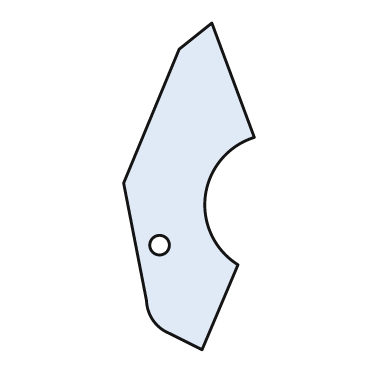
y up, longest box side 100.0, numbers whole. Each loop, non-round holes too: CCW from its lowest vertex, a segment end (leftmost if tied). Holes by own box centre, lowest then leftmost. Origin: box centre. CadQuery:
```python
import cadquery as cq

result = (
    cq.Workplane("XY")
    .moveTo(4.0, -50.0)
    .lineTo(15.0, -24.0)
    .threePointArc((5.0, -3.0), (20.0, 15.0))
    .lineTo(7.0, 50.0)
    .lineTo(-3.0, 42.0)
    .lineTo(-20.0, 1.0)
    .lineTo(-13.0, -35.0)
    .threePointArc((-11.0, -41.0), (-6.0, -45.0))
    .close()
    .moveTo(-9.0, -18.0)
    .circle(3.0)
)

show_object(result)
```